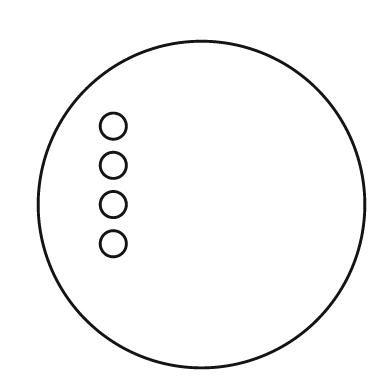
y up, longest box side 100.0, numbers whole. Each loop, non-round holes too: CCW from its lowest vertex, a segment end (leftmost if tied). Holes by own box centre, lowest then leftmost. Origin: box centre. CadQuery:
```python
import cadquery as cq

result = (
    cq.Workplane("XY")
    .moveTo(0.0, 0.0)
    .circle(50.0)
    .moveTo(-27.0, -12.0)
    .circle(4.0)
    .moveTo(-27.0, 0.0)
    .circle(4.0)
    .moveTo(-27.0, 12.0)
    .circle(4.0)
    .moveTo(-27.0, 24.0)
    .circle(4.0)
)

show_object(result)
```